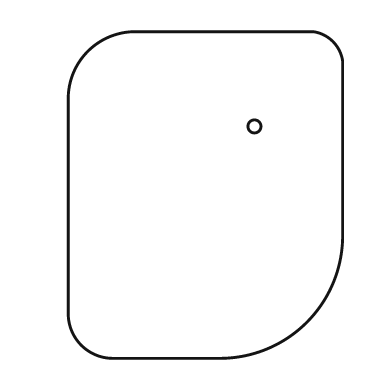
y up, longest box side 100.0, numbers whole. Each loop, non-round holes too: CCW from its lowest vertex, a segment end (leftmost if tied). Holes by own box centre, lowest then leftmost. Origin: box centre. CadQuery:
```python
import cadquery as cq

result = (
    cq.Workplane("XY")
    .moveTo(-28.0, -50.0)
    .lineTo(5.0, -50.0)
    .threePointArc((31.0, -39.0), (42.0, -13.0))
    .lineTo(42.0, 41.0)
    .threePointArc((39.0, 47.0), (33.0, 50.0))
    .lineTo(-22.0, 50.0)
    .threePointArc((-36.0, 44.0), (-42.0, 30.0))
    .lineTo(-42.0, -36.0)
    .threePointArc((-38.0, -46.0), (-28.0, -50.0))
    .close()
    .moveTo(15.0, 21.0)
    .circle(2.0)
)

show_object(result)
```